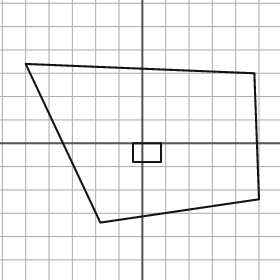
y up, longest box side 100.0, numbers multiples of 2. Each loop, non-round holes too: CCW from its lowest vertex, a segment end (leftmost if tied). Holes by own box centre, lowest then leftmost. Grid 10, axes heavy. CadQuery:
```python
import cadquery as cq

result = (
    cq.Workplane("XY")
    .moveTo(-18.0, -34.0)
    .lineTo(50.0, -24.0)
    .lineTo(48.0, 30.0)
    .lineTo(-50.0, 34.0)
    .close()
    .moveTo(-4.0, -8.0)
    .lineTo(8.0, -8.0)
    .lineTo(8.0, 0.0)
    .lineTo(-4.0, 0.0)
    .close()
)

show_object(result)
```